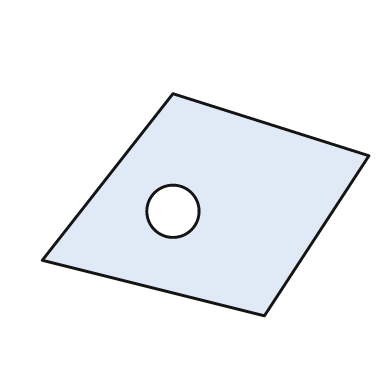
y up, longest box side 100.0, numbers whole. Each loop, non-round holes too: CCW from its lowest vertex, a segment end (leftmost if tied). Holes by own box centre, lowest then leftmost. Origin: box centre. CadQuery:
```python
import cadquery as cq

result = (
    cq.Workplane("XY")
    .moveTo(18.0, -34.0)
    .lineTo(50.0, 15.0)
    .lineTo(-10.0, 34.0)
    .lineTo(-50.0, -17.0)
    .close()
    .moveTo(-10.0, -2.0)
    .circle(8.0)
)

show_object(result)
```